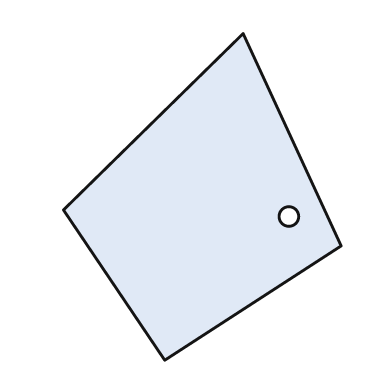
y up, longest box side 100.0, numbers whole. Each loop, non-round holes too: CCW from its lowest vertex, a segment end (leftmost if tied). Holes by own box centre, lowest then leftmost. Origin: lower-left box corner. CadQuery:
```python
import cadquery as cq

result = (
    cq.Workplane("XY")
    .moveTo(31.0, 0.0)
    .lineTo(85.0, 35.0)
    .lineTo(55.0, 100.0)
    .lineTo(0.0, 46.0)
    .close()
    .moveTo(69.0, 44.0)
    .circle(3.0)
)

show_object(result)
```